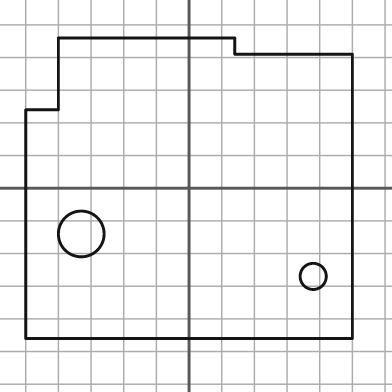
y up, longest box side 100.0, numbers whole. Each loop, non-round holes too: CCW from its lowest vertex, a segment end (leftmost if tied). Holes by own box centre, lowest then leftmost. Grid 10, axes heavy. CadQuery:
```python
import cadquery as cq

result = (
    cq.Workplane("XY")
    .moveTo(-50.0, -46.0)
    .lineTo(50.0, -46.0)
    .lineTo(50.0, 41.0)
    .lineTo(14.0, 41.0)
    .lineTo(14.0, 46.0)
    .lineTo(-40.0, 46.0)
    .lineTo(-40.0, 24.0)
    .lineTo(-50.0, 24.0)
    .close()
    .moveTo(38.0, -27.0)
    .circle(4.0)
    .moveTo(-33.0, -14.0)
    .circle(7.0)
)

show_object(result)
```